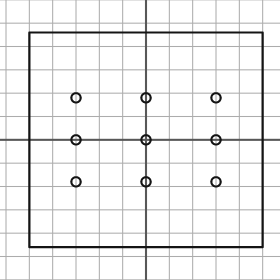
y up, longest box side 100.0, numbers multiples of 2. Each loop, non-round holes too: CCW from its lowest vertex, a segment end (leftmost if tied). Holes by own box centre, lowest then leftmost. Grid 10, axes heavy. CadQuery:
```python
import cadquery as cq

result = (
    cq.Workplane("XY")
    .moveTo(-50.0, -46.0)
    .lineTo(50.0, -46.0)
    .lineTo(50.0, 46.0)
    .lineTo(-50.0, 46.0)
    .close()
    .moveTo(-30.0, -18.0)
    .circle(2.0)
    .moveTo(0.0, -18.0)
    .circle(2.0)
    .moveTo(30.0, -18.0)
    .circle(2.0)
    .moveTo(-30.0, 0.0)
    .circle(2.0)
    .moveTo(0.0, 0.0)
    .circle(2.0)
    .moveTo(30.0, 0.0)
    .circle(2.0)
    .moveTo(-30.0, 18.0)
    .circle(2.0)
    .moveTo(0.0, 18.0)
    .circle(2.0)
    .moveTo(30.0, 18.0)
    .circle(2.0)
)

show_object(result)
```